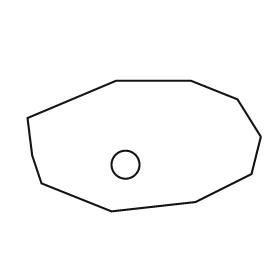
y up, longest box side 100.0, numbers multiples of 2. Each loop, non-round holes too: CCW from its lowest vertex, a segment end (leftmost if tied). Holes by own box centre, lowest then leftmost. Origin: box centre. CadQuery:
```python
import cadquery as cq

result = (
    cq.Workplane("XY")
    .moveTo(-14.0, -28.0)
    .lineTo(22.0, -24.0)
    .lineTo(46.0, -12.0)
    .lineTo(50.0, 4.0)
    .lineTo(40.0, 20.0)
    .lineTo(20.0, 28.0)
    .lineTo(-12.0, 28.0)
    .lineTo(-50.0, 12.0)
    .lineTo(-48.0, -4.0)
    .lineTo(-44.0, -16.0)
    .close()
    .moveTo(-8.0, -8.0)
    .circle(6.0)
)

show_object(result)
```